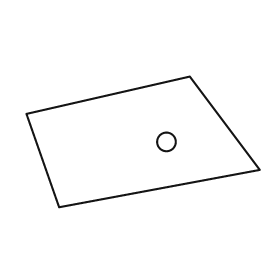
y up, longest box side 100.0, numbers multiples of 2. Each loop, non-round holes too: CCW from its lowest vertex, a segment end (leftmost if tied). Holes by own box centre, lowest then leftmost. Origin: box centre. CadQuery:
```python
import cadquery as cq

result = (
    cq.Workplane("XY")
    .moveTo(-36.0, -28.0)
    .lineTo(50.0, -12.0)
    .lineTo(20.0, 28.0)
    .lineTo(-50.0, 12.0)
    .close()
    .moveTo(10.0, 0.0)
    .circle(4.0)
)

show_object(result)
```